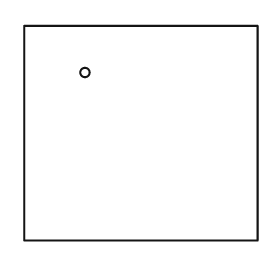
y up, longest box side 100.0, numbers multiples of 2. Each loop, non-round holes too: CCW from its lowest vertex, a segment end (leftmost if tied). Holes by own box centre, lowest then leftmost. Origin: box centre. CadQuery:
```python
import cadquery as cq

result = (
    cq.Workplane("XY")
    .moveTo(-50.0, -46.0)
    .lineTo(50.0, -46.0)
    .lineTo(50.0, 46.0)
    .lineTo(-50.0, 46.0)
    .close()
    .moveTo(-24.0, 26.0)
    .circle(2.0)
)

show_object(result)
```